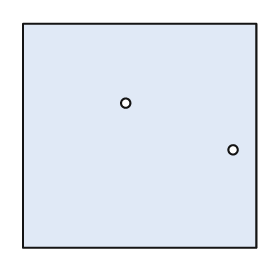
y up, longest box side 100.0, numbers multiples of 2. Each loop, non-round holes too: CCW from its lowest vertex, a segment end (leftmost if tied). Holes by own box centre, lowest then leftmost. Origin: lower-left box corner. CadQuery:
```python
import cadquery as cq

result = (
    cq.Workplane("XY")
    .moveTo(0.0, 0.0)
    .lineTo(100.0, 0.0)
    .lineTo(100.0, 96.0)
    .lineTo(0.0, 96.0)
    .close()
    .moveTo(90.0, 42.0)
    .circle(2.0)
    .moveTo(44.0, 62.0)
    .circle(2.0)
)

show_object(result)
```